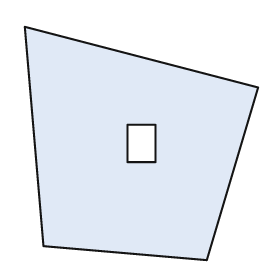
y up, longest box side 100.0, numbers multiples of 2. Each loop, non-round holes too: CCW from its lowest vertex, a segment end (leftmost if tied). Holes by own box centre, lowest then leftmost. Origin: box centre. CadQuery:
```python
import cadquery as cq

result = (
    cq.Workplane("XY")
    .moveTo(28.0, -50.0)
    .lineTo(50.0, 24.0)
    .lineTo(-50.0, 50.0)
    .lineTo(-42.0, -44.0)
    .close()
    .moveTo(-6.0, -8.0)
    .lineTo(6.0, -8.0)
    .lineTo(6.0, 8.0)
    .lineTo(-6.0, 8.0)
    .close()
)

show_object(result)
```